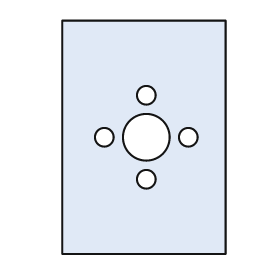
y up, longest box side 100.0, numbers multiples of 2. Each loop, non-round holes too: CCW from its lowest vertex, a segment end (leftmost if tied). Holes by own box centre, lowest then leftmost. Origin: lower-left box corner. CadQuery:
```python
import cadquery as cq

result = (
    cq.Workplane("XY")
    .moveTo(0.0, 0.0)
    .lineTo(70.0, 0.0)
    .lineTo(70.0, 100.0)
    .lineTo(0.0, 100.0)
    .close()
    .moveTo(36.0, 32.0)
    .circle(4.0)
    .moveTo(18.0, 50.0)
    .circle(4.0)
    .moveTo(36.0, 50.0)
    .circle(10.0)
    .moveTo(54.0, 50.0)
    .circle(4.0)
    .moveTo(36.0, 68.0)
    .circle(4.0)
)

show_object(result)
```